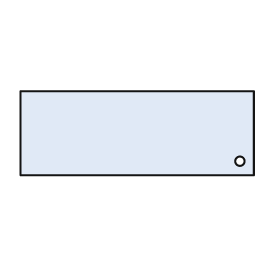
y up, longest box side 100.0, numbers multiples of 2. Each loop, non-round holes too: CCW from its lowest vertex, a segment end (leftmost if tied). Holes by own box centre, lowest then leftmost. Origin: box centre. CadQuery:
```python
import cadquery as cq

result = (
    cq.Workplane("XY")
    .moveTo(-50.0, -18.0)
    .lineTo(50.0, -18.0)
    .lineTo(50.0, 18.0)
    .lineTo(-50.0, 18.0)
    .close()
    .moveTo(44.0, -12.0)
    .circle(2.0)
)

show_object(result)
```